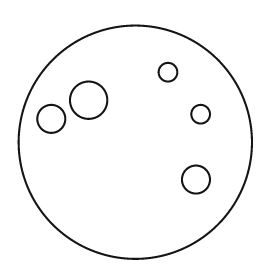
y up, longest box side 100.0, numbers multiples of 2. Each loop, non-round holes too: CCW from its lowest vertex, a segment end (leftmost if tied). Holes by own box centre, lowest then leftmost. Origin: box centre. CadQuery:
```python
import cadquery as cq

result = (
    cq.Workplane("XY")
    .moveTo(0.0, 0.0)
    .circle(50.0)
    .moveTo(26.0, -16.0)
    .circle(6.0)
    .moveTo(-36.0, 10.0)
    .circle(6.0)
    .moveTo(28.0, 12.0)
    .circle(4.0)
    .moveTo(-20.0, 18.0)
    .circle(8.0)
    .moveTo(14.0, 30.0)
    .circle(4.0)
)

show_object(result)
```